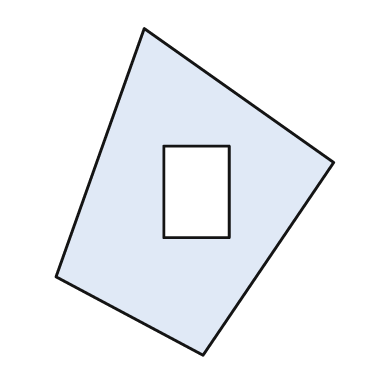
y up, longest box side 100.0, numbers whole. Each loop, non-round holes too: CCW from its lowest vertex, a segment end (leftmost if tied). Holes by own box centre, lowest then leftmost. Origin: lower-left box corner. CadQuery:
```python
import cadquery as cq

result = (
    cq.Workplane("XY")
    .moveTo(45.0, 0.0)
    .lineTo(85.0, 59.0)
    .lineTo(27.0, 100.0)
    .lineTo(0.0, 24.0)
    .close()
    .moveTo(33.0, 36.0)
    .lineTo(53.0, 36.0)
    .lineTo(53.0, 64.0)
    .lineTo(33.0, 64.0)
    .close()
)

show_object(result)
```